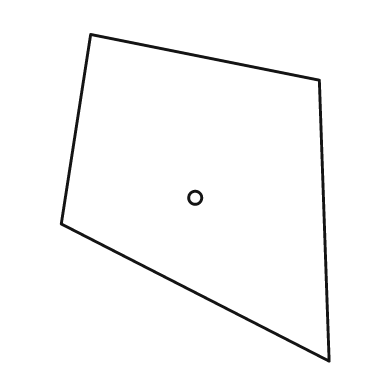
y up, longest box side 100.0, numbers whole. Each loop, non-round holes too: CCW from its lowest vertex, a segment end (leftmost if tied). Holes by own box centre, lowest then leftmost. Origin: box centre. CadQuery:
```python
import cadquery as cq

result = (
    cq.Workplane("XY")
    .moveTo(41.0, -50.0)
    .lineTo(38.0, 36.0)
    .lineTo(-32.0, 50.0)
    .lineTo(-41.0, -8.0)
    .close()
    .moveTo(0.0, 0.0)
    .circle(2.0)
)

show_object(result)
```